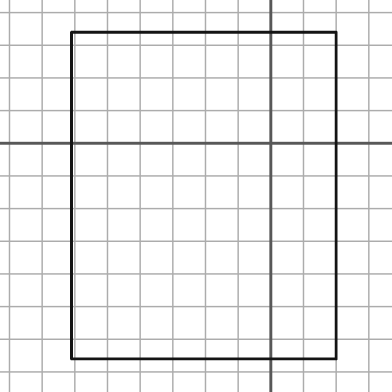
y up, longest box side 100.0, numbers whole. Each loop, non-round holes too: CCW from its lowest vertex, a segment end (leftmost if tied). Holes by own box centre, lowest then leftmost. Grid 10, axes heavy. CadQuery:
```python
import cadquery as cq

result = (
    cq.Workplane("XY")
    .moveTo(-61.0, -66.0)
    .lineTo(20.0, -66.0)
    .lineTo(20.0, 34.0)
    .lineTo(-61.0, 34.0)
    .close()
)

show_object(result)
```